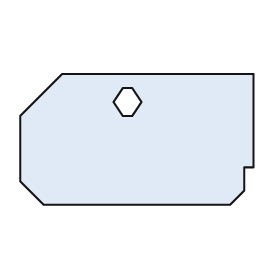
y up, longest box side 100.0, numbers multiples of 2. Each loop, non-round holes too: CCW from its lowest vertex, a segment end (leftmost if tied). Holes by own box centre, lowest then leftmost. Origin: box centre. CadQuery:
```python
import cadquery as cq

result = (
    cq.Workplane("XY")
    .moveTo(-40.0, -28.0)
    .lineTo(40.0, -28.0)
    .lineTo(46.0, -22.0)
    .lineTo(46.0, -12.0)
    .lineTo(50.0, -12.0)
    .lineTo(50.0, 28.0)
    .lineTo(-32.0, 28.0)
    .lineTo(-50.0, 10.0)
    .lineTo(-50.0, -18.0)
    .close()
    .moveTo(-6.0, 10.0)
    .lineTo(-2.0, 10.0)
    .lineTo(2.0, 16.0)
    .lineTo(-2.0, 22.0)
    .lineTo(-6.0, 22.0)
    .lineTo(-10.0, 16.0)
    .close()
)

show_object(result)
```